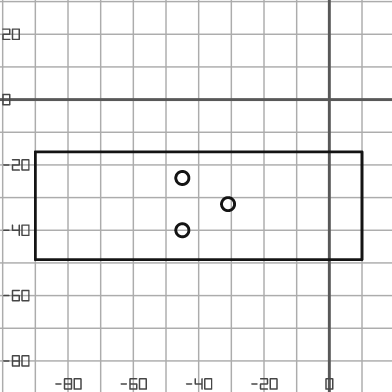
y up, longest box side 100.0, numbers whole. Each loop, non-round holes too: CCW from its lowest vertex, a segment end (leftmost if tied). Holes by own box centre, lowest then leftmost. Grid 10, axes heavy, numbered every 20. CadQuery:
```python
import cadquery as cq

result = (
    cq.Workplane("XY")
    .moveTo(-90.0, -49.0)
    .lineTo(10.0, -49.0)
    .lineTo(10.0, -16.0)
    .lineTo(-90.0, -16.0)
    .close()
    .moveTo(-45.0, -40.0)
    .circle(2.0)
    .moveTo(-31.0, -32.0)
    .circle(2.0)
    .moveTo(-45.0, -24.0)
    .circle(2.0)
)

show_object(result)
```